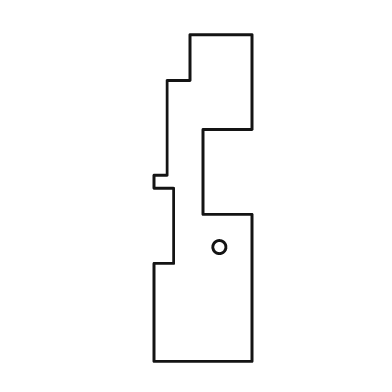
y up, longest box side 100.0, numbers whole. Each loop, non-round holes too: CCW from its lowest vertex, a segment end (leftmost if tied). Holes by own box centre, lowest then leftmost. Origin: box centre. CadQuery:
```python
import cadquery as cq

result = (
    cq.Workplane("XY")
    .moveTo(-15.0, -50.0)
    .lineTo(15.0, -50.0)
    .lineTo(15.0, -5.0)
    .lineTo(0.0, -5.0)
    .lineTo(0.0, 21.0)
    .lineTo(15.0, 21.0)
    .lineTo(15.0, 50.0)
    .lineTo(-4.0, 50.0)
    .lineTo(-4.0, 36.0)
    .lineTo(-11.0, 36.0)
    .lineTo(-11.0, 7.0)
    .lineTo(-15.0, 7.0)
    .lineTo(-15.0, 3.0)
    .lineTo(-9.0, 3.0)
    .lineTo(-9.0, -20.0)
    .lineTo(-15.0, -20.0)
    .close()
    .moveTo(5.0, -15.0)
    .circle(2.0)
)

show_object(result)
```